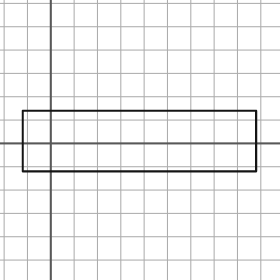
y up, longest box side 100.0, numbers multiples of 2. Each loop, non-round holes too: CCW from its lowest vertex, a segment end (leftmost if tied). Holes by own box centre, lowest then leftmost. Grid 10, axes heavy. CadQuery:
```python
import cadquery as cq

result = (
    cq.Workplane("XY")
    .moveTo(-12.0, -12.0)
    .lineTo(88.0, -12.0)
    .lineTo(88.0, 14.0)
    .lineTo(-12.0, 14.0)
    .close()
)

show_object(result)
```